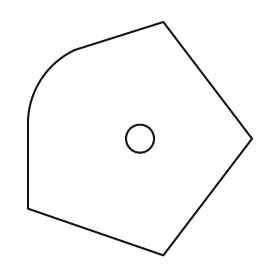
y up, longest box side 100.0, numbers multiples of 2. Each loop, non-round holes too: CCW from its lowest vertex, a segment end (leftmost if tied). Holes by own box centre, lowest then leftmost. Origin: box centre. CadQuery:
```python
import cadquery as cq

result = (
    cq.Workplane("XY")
    .moveTo(10.0, -50.0)
    .lineTo(48.0, 0.0)
    .lineTo(10.0, 50.0)
    .lineTo(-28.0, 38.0)
    .threePointArc((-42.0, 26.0), (-48.0, 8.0))
    .lineTo(-48.0, -30.0)
    .close()
    .moveTo(0.0, 0.0)
    .circle(6.0)
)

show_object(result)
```